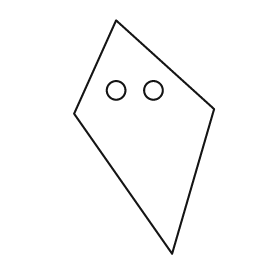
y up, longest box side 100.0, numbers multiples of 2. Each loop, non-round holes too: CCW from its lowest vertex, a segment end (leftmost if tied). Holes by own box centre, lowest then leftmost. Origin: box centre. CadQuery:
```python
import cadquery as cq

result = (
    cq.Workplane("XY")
    .moveTo(12.0, -50.0)
    .lineTo(30.0, 12.0)
    .lineTo(-12.0, 50.0)
    .lineTo(-30.0, 10.0)
    .close()
    .moveTo(-12.0, 20.0)
    .circle(4.0)
    .moveTo(4.0, 20.0)
    .circle(4.0)
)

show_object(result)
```